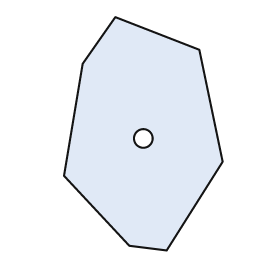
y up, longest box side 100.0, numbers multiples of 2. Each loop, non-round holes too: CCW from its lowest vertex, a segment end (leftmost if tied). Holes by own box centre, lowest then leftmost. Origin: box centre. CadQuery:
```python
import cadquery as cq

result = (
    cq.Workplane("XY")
    .moveTo(10.0, -50.0)
    .lineTo(34.0, -12.0)
    .lineTo(24.0, 36.0)
    .lineTo(-12.0, 50.0)
    .lineTo(-26.0, 30.0)
    .lineTo(-34.0, -18.0)
    .lineTo(-6.0, -48.0)
    .close()
    .moveTo(0.0, -2.0)
    .circle(4.0)
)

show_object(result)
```